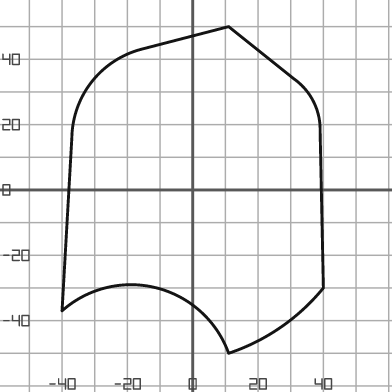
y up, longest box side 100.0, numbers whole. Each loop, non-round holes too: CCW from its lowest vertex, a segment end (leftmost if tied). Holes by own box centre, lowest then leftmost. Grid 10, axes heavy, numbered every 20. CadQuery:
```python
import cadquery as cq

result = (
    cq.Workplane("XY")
    .moveTo(11.0, -50.0)
    .threePointArc((27.0, -42.0), (40.0, -30.0))
    .lineTo(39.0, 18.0)
    .threePointArc((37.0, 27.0), (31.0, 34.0))
    .lineTo(11.0, 50.0)
    .lineTo(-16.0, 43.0)
    .threePointArc((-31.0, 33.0), (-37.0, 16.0))
    .lineTo(-40.0, -37.0)
    .threePointArc((-11.0, -30.0), (11.0, -50.0))
    .close()
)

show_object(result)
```